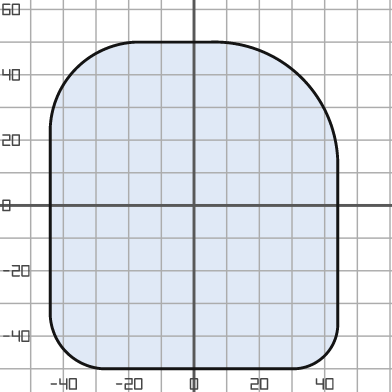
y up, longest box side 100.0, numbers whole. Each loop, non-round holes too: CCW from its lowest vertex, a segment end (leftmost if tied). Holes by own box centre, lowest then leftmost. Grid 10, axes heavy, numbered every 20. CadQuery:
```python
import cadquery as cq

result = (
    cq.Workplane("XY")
    .moveTo(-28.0, -50.0)
    .lineTo(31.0, -50.0)
    .threePointArc((40.0, -46.0), (44.0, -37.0))
    .lineTo(44.0, 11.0)
    .threePointArc((33.0, 39.0), (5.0, 50.0))
    .lineTo(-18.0, 50.0)
    .threePointArc((-36.0, 42.0), (-44.0, 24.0))
    .lineTo(-44.0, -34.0)
    .threePointArc((-39.0, -45.0), (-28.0, -50.0))
    .close()
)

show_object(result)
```